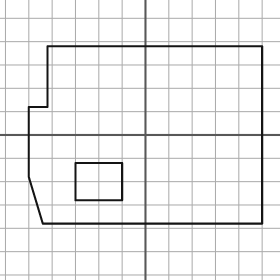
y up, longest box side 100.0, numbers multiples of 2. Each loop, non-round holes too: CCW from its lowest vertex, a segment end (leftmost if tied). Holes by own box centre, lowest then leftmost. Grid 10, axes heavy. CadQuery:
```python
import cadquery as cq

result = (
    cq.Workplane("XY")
    .moveTo(-44.0, -38.0)
    .lineTo(50.0, -38.0)
    .lineTo(50.0, 38.0)
    .lineTo(-42.0, 38.0)
    .lineTo(-42.0, 12.0)
    .lineTo(-50.0, 12.0)
    .lineTo(-50.0, -18.0)
    .close()
    .moveTo(-30.0, -28.0)
    .lineTo(-10.0, -28.0)
    .lineTo(-10.0, -12.0)
    .lineTo(-30.0, -12.0)
    .close()
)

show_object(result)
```